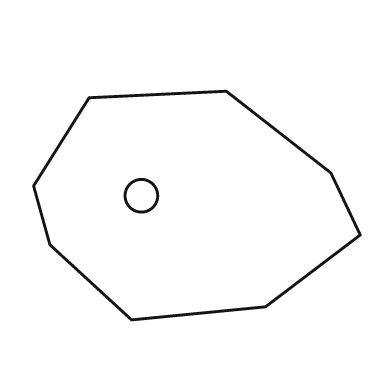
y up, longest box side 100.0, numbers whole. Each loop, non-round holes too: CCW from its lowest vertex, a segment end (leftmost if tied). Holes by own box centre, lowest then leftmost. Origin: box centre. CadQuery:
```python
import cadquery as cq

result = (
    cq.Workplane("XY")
    .moveTo(-20.0, -35.0)
    .lineTo(21.0, -31.0)
    .lineTo(50.0, -9.0)
    .lineTo(41.0, 10.0)
    .lineTo(9.0, 35.0)
    .lineTo(-33.0, 33.0)
    .lineTo(-50.0, 6.0)
    .lineTo(-45.0, -12.0)
    .close()
    .moveTo(-17.0, 3.0)
    .circle(5.0)
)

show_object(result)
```